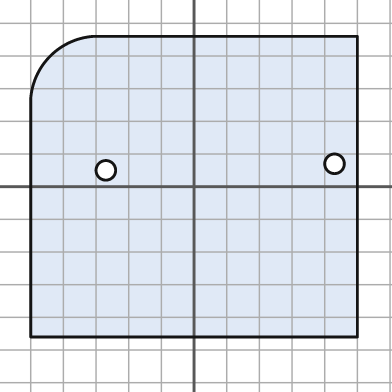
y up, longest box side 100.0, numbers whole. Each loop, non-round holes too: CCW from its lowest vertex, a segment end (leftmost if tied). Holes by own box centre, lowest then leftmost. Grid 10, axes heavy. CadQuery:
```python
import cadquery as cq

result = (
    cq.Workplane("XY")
    .moveTo(-50.0, -46.0)
    .lineTo(50.0, -46.0)
    .lineTo(50.0, 46.0)
    .lineTo(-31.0, 46.0)
    .threePointArc((-44.0, 40.0), (-50.0, 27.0))
    .close()
    .moveTo(-27.0, 5.0)
    .circle(3.0)
    .moveTo(43.0, 7.0)
    .circle(3.0)
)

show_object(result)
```